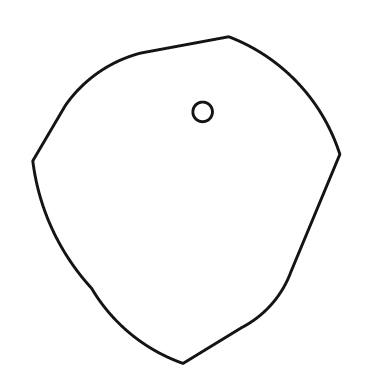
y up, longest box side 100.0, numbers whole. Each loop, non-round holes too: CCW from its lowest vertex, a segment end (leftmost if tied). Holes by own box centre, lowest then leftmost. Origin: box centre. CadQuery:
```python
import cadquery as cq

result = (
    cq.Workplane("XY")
    .moveTo(-1.0, -50.0)
    .lineTo(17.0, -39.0)
    .threePointArc((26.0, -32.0), (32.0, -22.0))
    .lineTo(47.0, 14.0)
    .threePointArc((34.0, 36.0), (13.0, 50.0))
    .lineTo(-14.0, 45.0)
    .threePointArc((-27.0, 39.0), (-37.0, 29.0))
    .lineTo(-47.0, 12.0)
    .threePointArc((-41.0, -9.0), (-29.0, -27.0))
    .threePointArc((-17.0, -41.0), (-1.0, -50.0))
    .close()
    .moveTo(5.0, 27.0)
    .circle(3.0)
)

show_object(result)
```